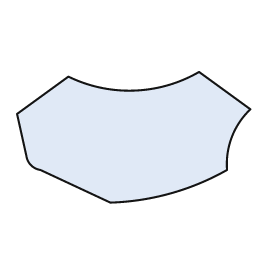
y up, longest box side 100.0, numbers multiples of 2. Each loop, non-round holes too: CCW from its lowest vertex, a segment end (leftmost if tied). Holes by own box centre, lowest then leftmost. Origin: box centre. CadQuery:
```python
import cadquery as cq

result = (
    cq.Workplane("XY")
    .moveTo(-10.0, -28.0)
    .threePointArc((16.0, -24.0), (40.0, -14.0))
    .threePointArc((42.0, 0.0), (50.0, 12.0))
    .lineTo(28.0, 28.0)
    .threePointArc((0.0, 20.0), (-28.0, 26.0))
    .lineTo(-50.0, 10.0)
    .lineTo(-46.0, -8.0)
    .threePointArc((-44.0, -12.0), (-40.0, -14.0))
    .close()
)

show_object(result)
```